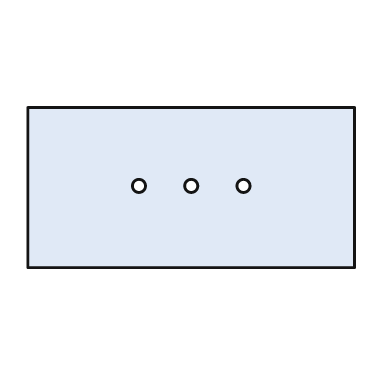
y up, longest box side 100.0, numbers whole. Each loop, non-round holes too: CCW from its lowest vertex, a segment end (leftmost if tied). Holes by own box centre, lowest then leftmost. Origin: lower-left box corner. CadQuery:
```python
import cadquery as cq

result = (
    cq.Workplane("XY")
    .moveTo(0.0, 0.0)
    .lineTo(100.0, 0.0)
    .lineTo(100.0, 49.0)
    .lineTo(0.0, 49.0)
    .close()
    .moveTo(34.0, 25.0)
    .circle(2.0)
    .moveTo(50.0, 25.0)
    .circle(2.0)
    .moveTo(66.0, 25.0)
    .circle(2.0)
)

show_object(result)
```